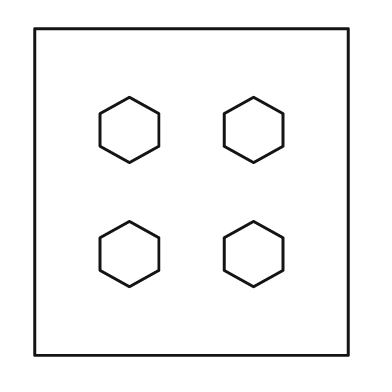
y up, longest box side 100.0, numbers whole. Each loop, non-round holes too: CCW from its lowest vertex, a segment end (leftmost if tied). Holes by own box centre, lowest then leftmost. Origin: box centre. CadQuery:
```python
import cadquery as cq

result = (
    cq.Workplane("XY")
    .moveTo(-48.0, -50.0)
    .lineTo(48.0, -50.0)
    .lineTo(48.0, 50.0)
    .lineTo(-48.0, 50.0)
    .close()
    .moveTo(-19.0, -29.0)
    .lineTo(-10.0, -24.0)
    .lineTo(-10.0, -14.0)
    .lineTo(-19.0, -9.0)
    .lineTo(-28.0, -14.0)
    .lineTo(-28.0, -24.0)
    .close()
    .moveTo(19.0, -29.0)
    .lineTo(28.0, -24.0)
    .lineTo(28.0, -14.0)
    .lineTo(19.0, -9.0)
    .lineTo(10.0, -14.0)
    .lineTo(10.0, -24.0)
    .close()
    .moveTo(-19.0, 9.0)
    .lineTo(-10.0, 14.0)
    .lineTo(-10.0, 24.0)
    .lineTo(-19.0, 29.0)
    .lineTo(-28.0, 24.0)
    .lineTo(-28.0, 14.0)
    .close()
    .moveTo(19.0, 9.0)
    .lineTo(28.0, 14.0)
    .lineTo(28.0, 24.0)
    .lineTo(19.0, 29.0)
    .lineTo(10.0, 24.0)
    .lineTo(10.0, 14.0)
    .close()
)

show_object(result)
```